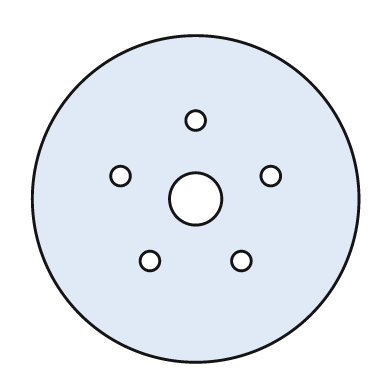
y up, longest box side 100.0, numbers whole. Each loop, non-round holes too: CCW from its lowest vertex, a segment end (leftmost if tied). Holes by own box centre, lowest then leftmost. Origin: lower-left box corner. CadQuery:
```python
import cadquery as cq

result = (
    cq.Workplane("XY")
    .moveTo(50.0, 50.0)
    .circle(50.0)
    .moveTo(36.0, 31.0)
    .circle(3.0)
    .moveTo(64.0, 31.0)
    .circle(3.0)
    .moveTo(50.0, 50.0)
    .circle(8.0)
    .moveTo(27.0, 57.0)
    .circle(3.0)
    .moveTo(73.0, 57.0)
    .circle(3.0)
    .moveTo(50.0, 74.0)
    .circle(3.0)
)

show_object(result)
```